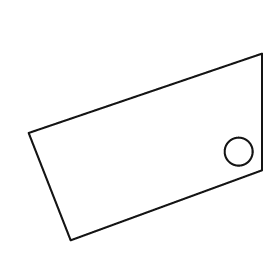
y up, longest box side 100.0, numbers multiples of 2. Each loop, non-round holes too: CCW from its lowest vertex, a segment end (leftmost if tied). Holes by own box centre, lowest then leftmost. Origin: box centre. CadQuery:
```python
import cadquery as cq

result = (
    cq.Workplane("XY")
    .moveTo(-32.0, -40.0)
    .lineTo(50.0, -10.0)
    .lineTo(50.0, 40.0)
    .lineTo(-50.0, 6.0)
    .close()
    .moveTo(40.0, -2.0)
    .circle(6.0)
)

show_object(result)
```